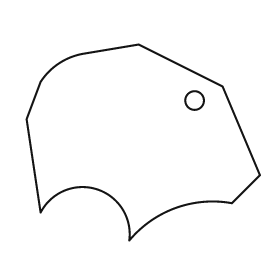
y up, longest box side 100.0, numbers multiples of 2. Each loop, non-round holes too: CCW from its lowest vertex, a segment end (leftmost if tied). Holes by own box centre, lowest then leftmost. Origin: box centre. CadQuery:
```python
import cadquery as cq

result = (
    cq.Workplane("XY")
    .moveTo(-6.0, -42.0)
    .threePointArc((14.0, -28.0), (38.0, -26.0))
    .lineTo(50.0, -14.0)
    .lineTo(34.0, 24.0)
    .lineTo(-2.0, 42.0)
    .lineTo(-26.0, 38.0)
    .threePointArc((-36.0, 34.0), (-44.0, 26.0))
    .lineTo(-50.0, 10.0)
    .lineTo(-44.0, -30.0)
    .threePointArc((-20.0, -20.0), (-6.0, -42.0))
    .close()
    .moveTo(22.0, 18.0)
    .circle(4.0)
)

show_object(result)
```